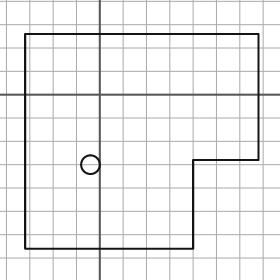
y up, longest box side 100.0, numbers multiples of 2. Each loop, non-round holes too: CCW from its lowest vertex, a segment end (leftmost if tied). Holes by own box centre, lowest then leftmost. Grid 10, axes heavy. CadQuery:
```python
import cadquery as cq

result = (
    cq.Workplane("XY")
    .moveTo(-32.0, -66.0)
    .lineTo(40.0, -66.0)
    .lineTo(40.0, -28.0)
    .lineTo(68.0, -28.0)
    .lineTo(68.0, 26.0)
    .lineTo(-32.0, 26.0)
    .close()
    .moveTo(-4.0, -30.0)
    .circle(4.0)
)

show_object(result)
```